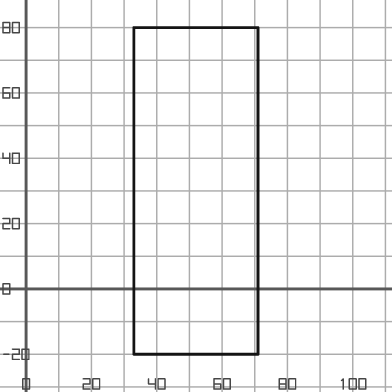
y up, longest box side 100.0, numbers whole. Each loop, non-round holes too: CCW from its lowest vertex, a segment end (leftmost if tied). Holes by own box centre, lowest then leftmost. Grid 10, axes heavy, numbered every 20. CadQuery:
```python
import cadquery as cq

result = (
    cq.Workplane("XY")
    .moveTo(33.0, -20.0)
    .lineTo(71.0, -20.0)
    .lineTo(71.0, 80.0)
    .lineTo(33.0, 80.0)
    .close()
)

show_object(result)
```